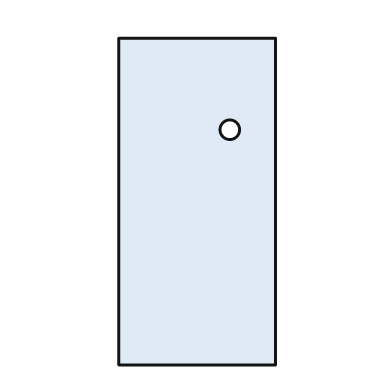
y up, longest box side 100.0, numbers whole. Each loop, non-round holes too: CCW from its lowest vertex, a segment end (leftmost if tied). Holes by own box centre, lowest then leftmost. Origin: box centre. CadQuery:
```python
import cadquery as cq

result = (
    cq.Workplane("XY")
    .moveTo(-24.0, -50.0)
    .lineTo(24.0, -50.0)
    .lineTo(24.0, 50.0)
    .lineTo(-24.0, 50.0)
    .close()
    .moveTo(10.0, 22.0)
    .circle(3.0)
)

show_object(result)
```